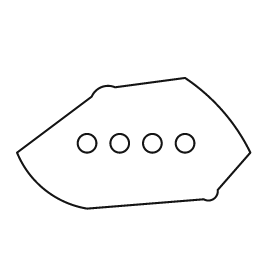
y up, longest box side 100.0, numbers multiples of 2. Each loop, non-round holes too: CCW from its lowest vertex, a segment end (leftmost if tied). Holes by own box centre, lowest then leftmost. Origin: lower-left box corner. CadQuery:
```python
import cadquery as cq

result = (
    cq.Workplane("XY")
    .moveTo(30.0, 0.0)
    .lineTo(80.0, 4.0)
    .threePointArc((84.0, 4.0), (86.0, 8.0))
    .lineTo(100.0, 24.0)
    .threePointArc((88.0, 42.0), (72.0, 56.0))
    .lineTo(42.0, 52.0)
    .threePointArc((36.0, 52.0), (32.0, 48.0))
    .lineTo(0.0, 24.0)
    .threePointArc((12.0, 8.0), (30.0, 0.0))
    .close()
    .moveTo(30.0, 28.0)
    .circle(4.0)
    .moveTo(44.0, 28.0)
    .circle(4.0)
    .moveTo(58.0, 28.0)
    .circle(4.0)
    .moveTo(72.0, 28.0)
    .circle(4.0)
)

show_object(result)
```